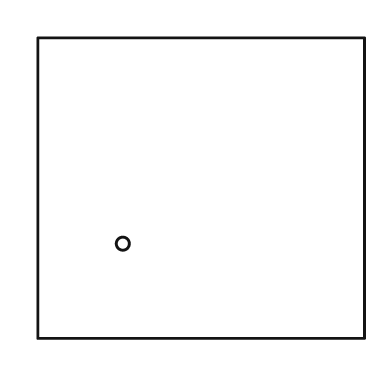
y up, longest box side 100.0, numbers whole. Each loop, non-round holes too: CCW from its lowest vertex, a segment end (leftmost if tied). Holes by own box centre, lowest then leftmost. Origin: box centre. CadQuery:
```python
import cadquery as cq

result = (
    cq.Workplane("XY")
    .moveTo(-50.0, -46.0)
    .lineTo(50.0, -46.0)
    .lineTo(50.0, 46.0)
    .lineTo(-50.0, 46.0)
    .close()
    .moveTo(-24.0, -17.0)
    .circle(2.0)
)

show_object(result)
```